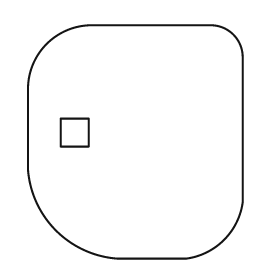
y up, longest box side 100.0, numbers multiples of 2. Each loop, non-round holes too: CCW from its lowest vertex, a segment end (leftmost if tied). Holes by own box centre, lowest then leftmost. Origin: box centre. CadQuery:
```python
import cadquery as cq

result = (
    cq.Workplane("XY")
    .moveTo(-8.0, -50.0)
    .lineTo(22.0, -50.0)
    .threePointArc((38.0, -42.0), (46.0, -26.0))
    .lineTo(46.0, 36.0)
    .threePointArc((42.0, 46.0), (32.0, 50.0))
    .lineTo(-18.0, 50.0)
    .threePointArc((-38.0, 42.0), (-46.0, 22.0))
    .lineTo(-46.0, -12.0)
    .threePointArc((-34.0, -38.0), (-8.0, -50.0))
    .close()
    .moveTo(-32.0, -2.0)
    .lineTo(-20.0, -2.0)
    .lineTo(-20.0, 10.0)
    .lineTo(-32.0, 10.0)
    .close()
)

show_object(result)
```